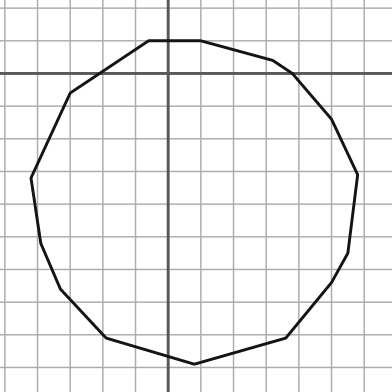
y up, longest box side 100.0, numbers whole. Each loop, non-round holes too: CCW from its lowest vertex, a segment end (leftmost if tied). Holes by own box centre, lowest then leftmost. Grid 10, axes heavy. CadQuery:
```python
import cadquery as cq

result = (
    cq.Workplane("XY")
    .moveTo(8.0, -89.0)
    .lineTo(36.0, -81.0)
    .lineTo(50.0, -64.0)
    .lineTo(55.0, -55.0)
    .lineTo(58.0, -31.0)
    .lineTo(50.0, -14.0)
    .lineTo(38.0, 0.0)
    .lineTo(32.0, 4.0)
    .lineTo(10.0, 10.0)
    .lineTo(-6.0, 10.0)
    .lineTo(-30.0, -6.0)
    .lineTo(-42.0, -32.0)
    .lineTo(-39.0, -52.0)
    .lineTo(-33.0, -66.0)
    .lineTo(-19.0, -81.0)
    .close()
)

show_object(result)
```